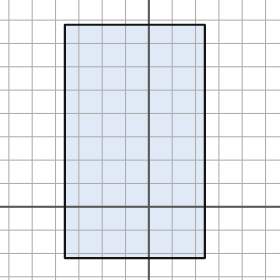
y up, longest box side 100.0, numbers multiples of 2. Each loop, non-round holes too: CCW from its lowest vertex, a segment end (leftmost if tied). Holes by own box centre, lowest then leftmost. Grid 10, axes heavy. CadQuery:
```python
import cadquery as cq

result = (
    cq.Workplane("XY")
    .moveTo(-36.0, -22.0)
    .lineTo(24.0, -22.0)
    .lineTo(24.0, 78.0)
    .lineTo(-36.0, 78.0)
    .close()
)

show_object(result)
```